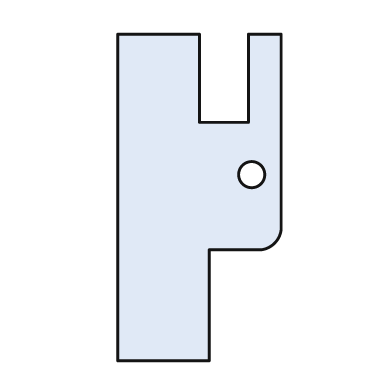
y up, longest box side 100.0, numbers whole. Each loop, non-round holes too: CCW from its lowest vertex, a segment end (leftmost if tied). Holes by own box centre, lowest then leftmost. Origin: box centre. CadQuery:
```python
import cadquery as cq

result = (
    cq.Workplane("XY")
    .moveTo(-25.0, -50.0)
    .lineTo(3.0, -50.0)
    .lineTo(3.0, -16.0)
    .lineTo(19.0, -16.0)
    .threePointArc((23.0, -14.0), (25.0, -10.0))
    .lineTo(25.0, 50.0)
    .lineTo(15.0, 50.0)
    .lineTo(15.0, 23.0)
    .lineTo(0.0, 23.0)
    .lineTo(0.0, 50.0)
    .lineTo(-25.0, 50.0)
    .close()
    .moveTo(16.0, 7.0)
    .circle(4.0)
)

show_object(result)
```